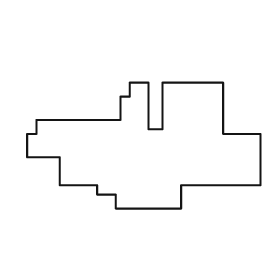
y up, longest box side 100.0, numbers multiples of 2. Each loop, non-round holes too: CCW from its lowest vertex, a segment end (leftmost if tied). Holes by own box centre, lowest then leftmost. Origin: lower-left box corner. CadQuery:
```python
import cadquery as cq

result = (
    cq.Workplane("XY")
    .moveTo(38.0, 0.0)
    .lineTo(66.0, 0.0)
    .lineTo(66.0, 10.0)
    .lineTo(100.0, 10.0)
    .lineTo(100.0, 32.0)
    .lineTo(84.0, 32.0)
    .lineTo(84.0, 54.0)
    .lineTo(58.0, 54.0)
    .lineTo(58.0, 34.0)
    .lineTo(52.0, 34.0)
    .lineTo(52.0, 54.0)
    .lineTo(44.0, 54.0)
    .lineTo(44.0, 48.0)
    .lineTo(40.0, 48.0)
    .lineTo(40.0, 38.0)
    .lineTo(4.0, 38.0)
    .lineTo(4.0, 32.0)
    .lineTo(0.0, 32.0)
    .lineTo(0.0, 22.0)
    .lineTo(14.0, 22.0)
    .lineTo(14.0, 10.0)
    .lineTo(30.0, 10.0)
    .lineTo(30.0, 6.0)
    .lineTo(38.0, 6.0)
    .close()
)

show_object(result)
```